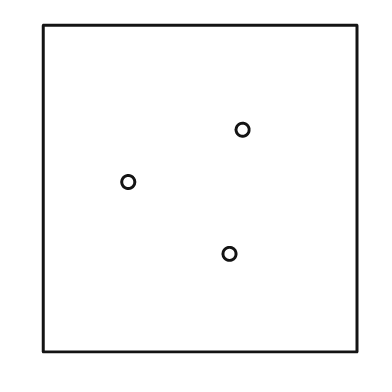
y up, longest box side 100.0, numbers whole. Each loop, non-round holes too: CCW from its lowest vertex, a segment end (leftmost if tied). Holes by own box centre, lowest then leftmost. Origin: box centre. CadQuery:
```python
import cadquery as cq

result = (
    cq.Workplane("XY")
    .moveTo(-48.0, -50.0)
    .lineTo(48.0, -50.0)
    .lineTo(48.0, 50.0)
    .lineTo(-48.0, 50.0)
    .close()
    .moveTo(9.0, -20.0)
    .circle(2.0)
    .moveTo(-22.0, 2.0)
    .circle(2.0)
    .moveTo(13.0, 18.0)
    .circle(2.0)
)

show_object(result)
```